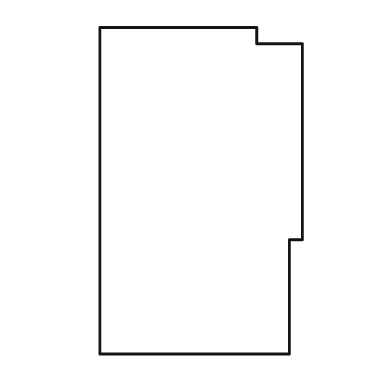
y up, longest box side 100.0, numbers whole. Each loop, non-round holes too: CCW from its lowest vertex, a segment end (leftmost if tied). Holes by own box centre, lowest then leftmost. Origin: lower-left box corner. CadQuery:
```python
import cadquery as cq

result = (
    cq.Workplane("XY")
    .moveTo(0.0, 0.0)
    .lineTo(58.0, 0.0)
    .lineTo(58.0, 35.0)
    .lineTo(62.0, 35.0)
    .lineTo(62.0, 95.0)
    .lineTo(48.0, 95.0)
    .lineTo(48.0, 100.0)
    .lineTo(0.0, 100.0)
    .close()
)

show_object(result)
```